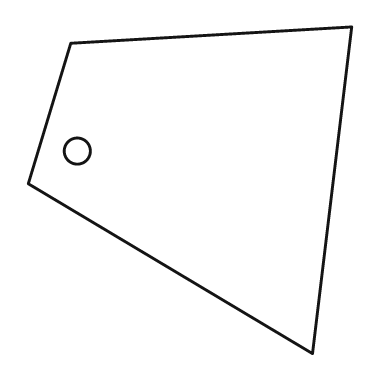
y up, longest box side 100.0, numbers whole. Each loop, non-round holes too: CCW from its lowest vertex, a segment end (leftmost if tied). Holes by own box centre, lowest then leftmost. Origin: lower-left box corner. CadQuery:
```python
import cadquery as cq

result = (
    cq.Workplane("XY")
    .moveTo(87.0, 0.0)
    .lineTo(99.0, 100.0)
    .lineTo(13.0, 95.0)
    .lineTo(0.0, 52.0)
    .close()
    .moveTo(15.0, 62.0)
    .circle(4.0)
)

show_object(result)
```